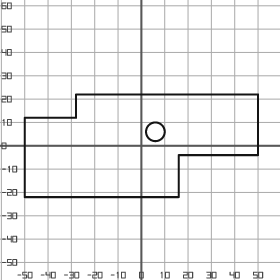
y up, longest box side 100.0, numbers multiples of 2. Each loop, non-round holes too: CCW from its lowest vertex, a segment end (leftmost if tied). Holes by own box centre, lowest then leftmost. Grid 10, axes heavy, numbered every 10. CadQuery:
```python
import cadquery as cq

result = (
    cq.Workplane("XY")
    .moveTo(-50.0, -22.0)
    .lineTo(16.0, -22.0)
    .lineTo(16.0, -4.0)
    .lineTo(50.0, -4.0)
    .lineTo(50.0, 22.0)
    .lineTo(-28.0, 22.0)
    .lineTo(-28.0, 12.0)
    .lineTo(-50.0, 12.0)
    .close()
    .moveTo(6.0, 6.0)
    .circle(4.0)
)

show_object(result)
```